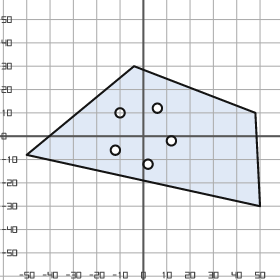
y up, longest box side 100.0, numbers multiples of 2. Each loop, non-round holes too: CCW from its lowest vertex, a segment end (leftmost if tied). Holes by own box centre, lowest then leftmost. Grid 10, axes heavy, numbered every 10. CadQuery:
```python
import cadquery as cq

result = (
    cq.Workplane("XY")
    .moveTo(50.0, -30.0)
    .lineTo(48.0, 10.0)
    .lineTo(-4.0, 30.0)
    .lineTo(-50.0, -8.0)
    .close()
    .moveTo(2.0, -12.0)
    .circle(2.0)
    .moveTo(-12.0, -6.0)
    .circle(2.0)
    .moveTo(12.0, -2.0)
    .circle(2.0)
    .moveTo(-10.0, 10.0)
    .circle(2.0)
    .moveTo(6.0, 12.0)
    .circle(2.0)
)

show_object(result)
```